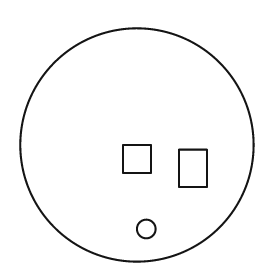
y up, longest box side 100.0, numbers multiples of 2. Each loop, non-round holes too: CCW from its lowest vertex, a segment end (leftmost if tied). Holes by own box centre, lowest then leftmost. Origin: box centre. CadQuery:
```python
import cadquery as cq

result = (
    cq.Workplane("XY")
    .moveTo(0.0, 0.0)
    .circle(50.0)
    .moveTo(4.0, -36.0)
    .circle(4.0)
    .moveTo(18.0, -18.0)
    .lineTo(30.0, -18.0)
    .lineTo(30.0, -2.0)
    .lineTo(18.0, -2.0)
    .close()
    .moveTo(-6.0, -12.0)
    .lineTo(6.0, -12.0)
    .lineTo(6.0, 0.0)
    .lineTo(-6.0, 0.0)
    .close()
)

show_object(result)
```